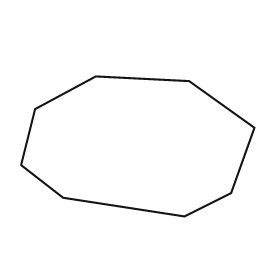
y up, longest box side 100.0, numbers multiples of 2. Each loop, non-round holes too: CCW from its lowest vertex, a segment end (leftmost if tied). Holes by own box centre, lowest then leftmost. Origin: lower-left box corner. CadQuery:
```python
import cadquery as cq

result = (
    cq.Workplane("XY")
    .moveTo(70.0, 0.0)
    .lineTo(90.0, 10.0)
    .lineTo(100.0, 38.0)
    .lineTo(72.0, 58.0)
    .lineTo(32.0, 60.0)
    .lineTo(6.0, 46.0)
    .lineTo(0.0, 22.0)
    .lineTo(18.0, 8.0)
    .close()
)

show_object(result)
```